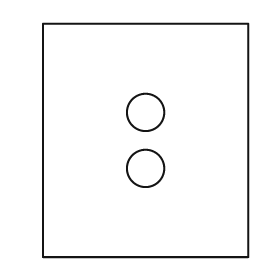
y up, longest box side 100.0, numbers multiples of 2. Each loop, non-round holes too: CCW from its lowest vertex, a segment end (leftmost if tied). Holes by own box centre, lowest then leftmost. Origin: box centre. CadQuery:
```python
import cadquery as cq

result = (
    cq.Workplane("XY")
    .moveTo(-44.0, -50.0)
    .lineTo(44.0, -50.0)
    .lineTo(44.0, 50.0)
    .lineTo(-44.0, 50.0)
    .close()
    .moveTo(0.0, -12.0)
    .circle(8.0)
    .moveTo(0.0, 12.0)
    .circle(8.0)
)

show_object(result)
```